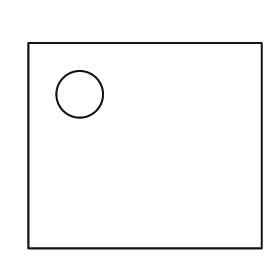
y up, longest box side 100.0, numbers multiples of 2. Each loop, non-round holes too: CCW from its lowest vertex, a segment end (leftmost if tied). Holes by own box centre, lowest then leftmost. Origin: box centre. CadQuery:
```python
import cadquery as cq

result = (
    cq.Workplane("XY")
    .moveTo(-50.0, -44.0)
    .lineTo(50.0, -44.0)
    .lineTo(50.0, 44.0)
    .lineTo(-50.0, 44.0)
    .close()
    .moveTo(-28.0, 22.0)
    .circle(10.0)
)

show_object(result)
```